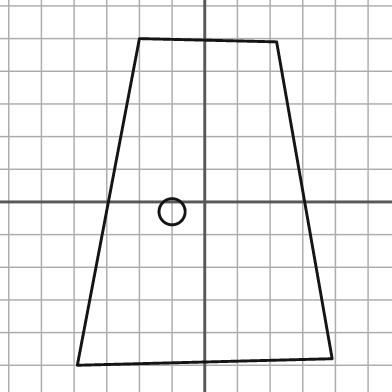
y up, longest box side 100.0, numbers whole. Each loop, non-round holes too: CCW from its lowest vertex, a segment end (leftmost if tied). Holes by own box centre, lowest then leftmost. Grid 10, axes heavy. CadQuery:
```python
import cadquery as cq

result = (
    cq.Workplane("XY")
    .moveTo(-39.0, -50.0)
    .lineTo(39.0, -48.0)
    .lineTo(22.0, 49.0)
    .lineTo(-20.0, 50.0)
    .close()
    .moveTo(-10.0, -3.0)
    .circle(4.0)
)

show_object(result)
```